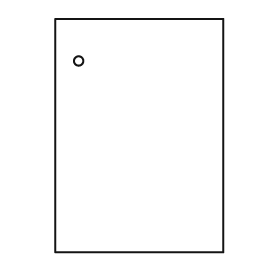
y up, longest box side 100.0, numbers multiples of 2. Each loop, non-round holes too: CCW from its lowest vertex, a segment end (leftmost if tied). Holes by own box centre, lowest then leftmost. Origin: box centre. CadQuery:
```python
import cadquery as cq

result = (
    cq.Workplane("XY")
    .moveTo(-36.0, -50.0)
    .lineTo(36.0, -50.0)
    .lineTo(36.0, 50.0)
    .lineTo(-36.0, 50.0)
    .close()
    .moveTo(-26.0, 32.0)
    .circle(2.0)
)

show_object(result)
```